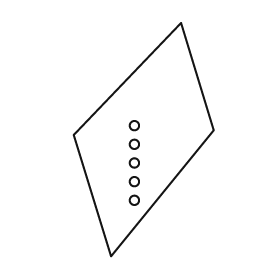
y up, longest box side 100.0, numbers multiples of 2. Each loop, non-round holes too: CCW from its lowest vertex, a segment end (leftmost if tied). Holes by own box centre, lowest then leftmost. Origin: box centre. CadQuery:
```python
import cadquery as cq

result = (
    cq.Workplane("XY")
    .moveTo(-14.0, -50.0)
    .lineTo(30.0, 4.0)
    .lineTo(16.0, 50.0)
    .lineTo(-30.0, 2.0)
    .close()
    .moveTo(-4.0, -26.0)
    .circle(2.0)
    .moveTo(-4.0, -18.0)
    .circle(2.0)
    .moveTo(-4.0, -10.0)
    .circle(2.0)
    .moveTo(-4.0, -2.0)
    .circle(2.0)
    .moveTo(-4.0, 6.0)
    .circle(2.0)
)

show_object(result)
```